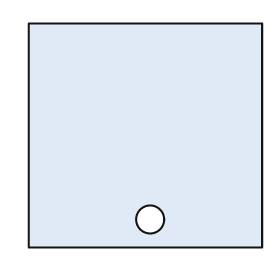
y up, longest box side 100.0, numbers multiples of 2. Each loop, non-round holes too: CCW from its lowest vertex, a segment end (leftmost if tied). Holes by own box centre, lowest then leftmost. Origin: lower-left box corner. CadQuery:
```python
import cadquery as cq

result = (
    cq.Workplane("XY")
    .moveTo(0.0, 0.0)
    .lineTo(100.0, 0.0)
    .lineTo(100.0, 96.0)
    .lineTo(0.0, 96.0)
    .close()
    .moveTo(52.0, 12.0)
    .circle(6.0)
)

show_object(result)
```